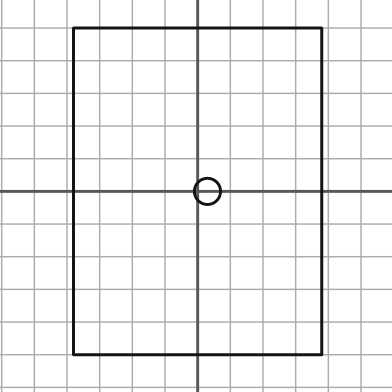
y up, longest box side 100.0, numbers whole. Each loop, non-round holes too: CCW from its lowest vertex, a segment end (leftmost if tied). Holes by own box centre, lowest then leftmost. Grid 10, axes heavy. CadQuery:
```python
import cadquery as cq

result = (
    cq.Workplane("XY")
    .moveTo(-38.0, -50.0)
    .lineTo(38.0, -50.0)
    .lineTo(38.0, 50.0)
    .lineTo(-38.0, 50.0)
    .close()
    .moveTo(3.0, 0.0)
    .circle(4.0)
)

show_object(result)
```